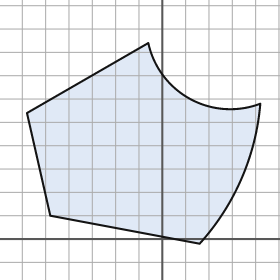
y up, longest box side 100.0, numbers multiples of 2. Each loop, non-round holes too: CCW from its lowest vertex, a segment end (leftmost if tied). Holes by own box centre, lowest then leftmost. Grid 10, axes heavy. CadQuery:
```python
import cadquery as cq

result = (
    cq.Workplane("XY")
    .moveTo(16.0, -2.0)
    .threePointArc((34.0, 26.0), (42.0, 58.0))
    .threePointArc((12.0, 60.0), (-6.0, 84.0))
    .lineTo(-58.0, 54.0)
    .lineTo(-48.0, 10.0)
    .close()
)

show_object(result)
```